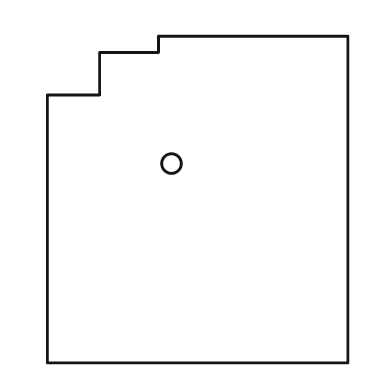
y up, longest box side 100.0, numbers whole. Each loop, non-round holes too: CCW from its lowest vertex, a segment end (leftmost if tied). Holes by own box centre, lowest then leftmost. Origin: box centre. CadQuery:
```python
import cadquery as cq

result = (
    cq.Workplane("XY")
    .moveTo(-46.0, -50.0)
    .lineTo(46.0, -50.0)
    .lineTo(46.0, 50.0)
    .lineTo(-12.0, 50.0)
    .lineTo(-12.0, 45.0)
    .lineTo(-30.0, 45.0)
    .lineTo(-30.0, 32.0)
    .lineTo(-46.0, 32.0)
    .close()
    .moveTo(-8.0, 11.0)
    .circle(3.0)
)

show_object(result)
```